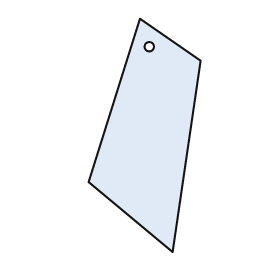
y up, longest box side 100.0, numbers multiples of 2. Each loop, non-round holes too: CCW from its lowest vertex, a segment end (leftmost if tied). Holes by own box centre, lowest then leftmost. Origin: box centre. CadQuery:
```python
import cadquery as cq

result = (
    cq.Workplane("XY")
    .moveTo(12.0, -50.0)
    .lineTo(24.0, 32.0)
    .lineTo(-2.0, 50.0)
    .lineTo(-24.0, -20.0)
    .close()
    .moveTo(2.0, 38.0)
    .circle(2.0)
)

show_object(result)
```